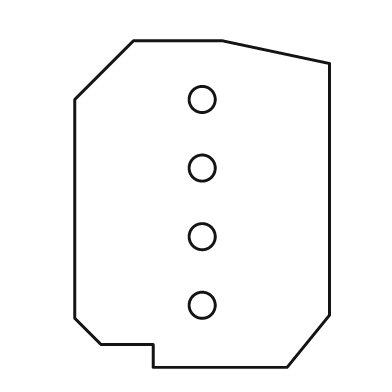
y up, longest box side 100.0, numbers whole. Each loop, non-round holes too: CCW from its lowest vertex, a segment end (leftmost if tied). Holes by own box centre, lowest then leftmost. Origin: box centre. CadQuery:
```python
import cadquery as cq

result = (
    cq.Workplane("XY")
    .moveTo(-15.0, -50.0)
    .lineTo(26.0, -50.0)
    .lineTo(39.0, -34.0)
    .lineTo(39.0, 43.0)
    .lineTo(6.0, 50.0)
    .lineTo(-21.0, 50.0)
    .lineTo(-39.0, 32.0)
    .lineTo(-39.0, -35.0)
    .lineTo(-31.0, -43.0)
    .lineTo(-15.0, -43.0)
    .close()
    .moveTo(0.0, -31.0)
    .circle(4.0)
    .moveTo(0.0, -10.0)
    .circle(4.0)
    .moveTo(0.0, 11.0)
    .circle(4.0)
    .moveTo(0.0, 32.0)
    .circle(4.0)
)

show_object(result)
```